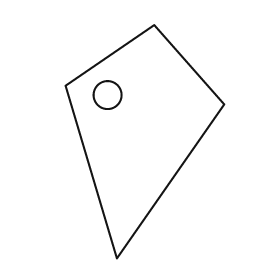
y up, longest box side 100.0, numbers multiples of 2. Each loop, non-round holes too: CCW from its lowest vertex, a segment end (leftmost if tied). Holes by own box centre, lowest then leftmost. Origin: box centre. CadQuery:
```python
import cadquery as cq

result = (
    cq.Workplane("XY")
    .moveTo(-12.0, -50.0)
    .lineTo(34.0, 16.0)
    .lineTo(4.0, 50.0)
    .lineTo(-34.0, 24.0)
    .close()
    .moveTo(-16.0, 20.0)
    .circle(6.0)
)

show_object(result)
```